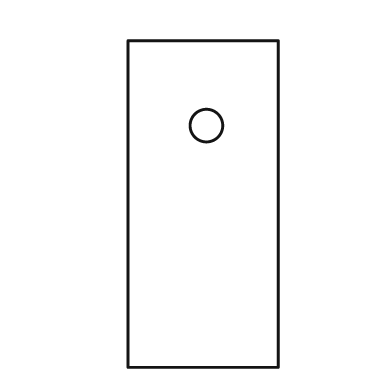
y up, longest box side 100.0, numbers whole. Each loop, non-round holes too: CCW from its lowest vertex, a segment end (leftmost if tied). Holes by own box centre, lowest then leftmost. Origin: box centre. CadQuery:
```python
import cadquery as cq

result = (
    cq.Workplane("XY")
    .moveTo(-23.0, -50.0)
    .lineTo(23.0, -50.0)
    .lineTo(23.0, 50.0)
    .lineTo(-23.0, 50.0)
    .close()
    .moveTo(1.0, 24.0)
    .circle(5.0)
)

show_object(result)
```